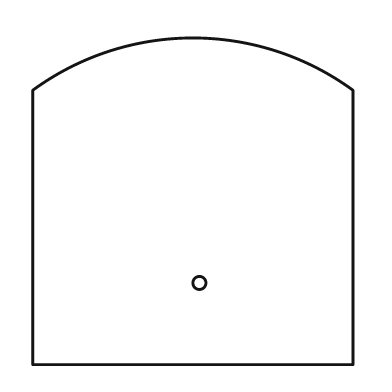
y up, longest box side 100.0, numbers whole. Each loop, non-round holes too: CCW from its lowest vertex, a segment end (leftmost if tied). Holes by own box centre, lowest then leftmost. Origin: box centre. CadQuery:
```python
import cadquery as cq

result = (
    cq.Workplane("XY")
    .moveTo(-49.0, -50.0)
    .lineTo(49.0, -50.0)
    .lineTo(49.0, 34.0)
    .threePointArc((0.0, 50.0), (-49.0, 34.0))
    .close()
    .moveTo(2.0, -25.0)
    .circle(2.0)
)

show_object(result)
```